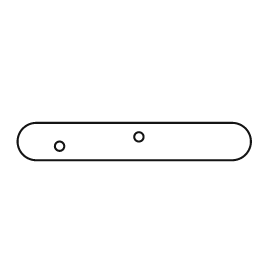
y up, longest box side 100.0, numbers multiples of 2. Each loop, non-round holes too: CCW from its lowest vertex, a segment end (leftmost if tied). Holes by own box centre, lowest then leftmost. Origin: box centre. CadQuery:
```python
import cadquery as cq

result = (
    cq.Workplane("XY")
    .moveTo(-42.0, -8.0)
    .lineTo(42.0, -8.0)
    .threePointArc((50.0, 0.0), (42.0, 8.0))
    .lineTo(-42.0, 8.0)
    .threePointArc((-50.0, 0.0), (-42.0, -8.0))
    .close()
    .moveTo(-32.0, -2.0)
    .circle(2.0)
    .moveTo(2.0, 2.0)
    .circle(2.0)
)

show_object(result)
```